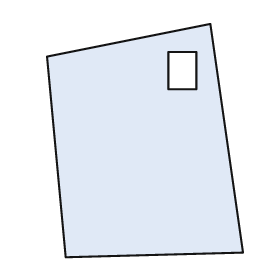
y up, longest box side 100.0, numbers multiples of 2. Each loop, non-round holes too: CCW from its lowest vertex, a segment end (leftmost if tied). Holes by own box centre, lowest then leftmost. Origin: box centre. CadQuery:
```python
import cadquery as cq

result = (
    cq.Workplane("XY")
    .moveTo(-34.0, -50.0)
    .lineTo(42.0, -48.0)
    .lineTo(28.0, 50.0)
    .lineTo(-42.0, 36.0)
    .close()
    .moveTo(10.0, 22.0)
    .lineTo(22.0, 22.0)
    .lineTo(22.0, 38.0)
    .lineTo(10.0, 38.0)
    .close()
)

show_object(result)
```